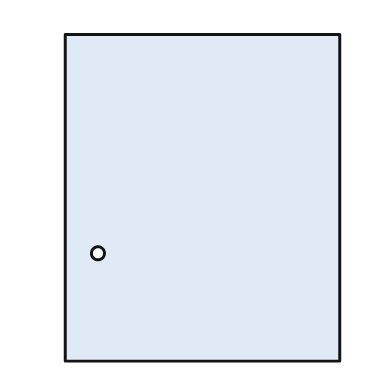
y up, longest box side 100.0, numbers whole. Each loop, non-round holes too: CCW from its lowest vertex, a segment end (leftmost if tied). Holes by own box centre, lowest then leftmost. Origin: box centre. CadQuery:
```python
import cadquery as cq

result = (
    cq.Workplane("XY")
    .moveTo(-42.0, -50.0)
    .lineTo(42.0, -50.0)
    .lineTo(42.0, 50.0)
    .lineTo(-42.0, 50.0)
    .close()
    .moveTo(-32.0, -17.0)
    .circle(2.0)
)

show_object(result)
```